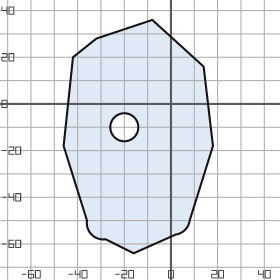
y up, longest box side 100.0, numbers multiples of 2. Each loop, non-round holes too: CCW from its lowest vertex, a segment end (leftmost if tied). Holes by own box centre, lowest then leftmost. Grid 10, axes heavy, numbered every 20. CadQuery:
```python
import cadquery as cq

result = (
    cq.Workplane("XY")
    .moveTo(-16.0, -64.0)
    .lineTo(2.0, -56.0)
    .threePointArc((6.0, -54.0), (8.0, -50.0))
    .lineTo(18.0, -18.0)
    .lineTo(14.0, 16.0)
    .lineTo(-8.0, 36.0)
    .lineTo(-32.0, 28.0)
    .lineTo(-42.0, 20.0)
    .lineTo(-46.0, -18.0)
    .lineTo(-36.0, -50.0)
    .threePointArc((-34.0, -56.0), (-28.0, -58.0))
    .close()
    .moveTo(-20.0, -10.0)
    .circle(6.0)
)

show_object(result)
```